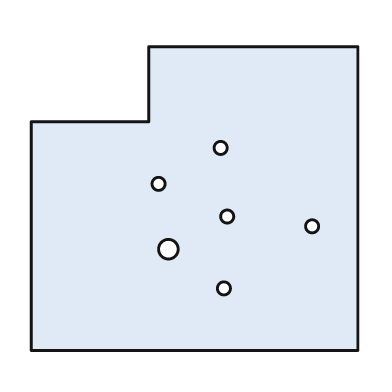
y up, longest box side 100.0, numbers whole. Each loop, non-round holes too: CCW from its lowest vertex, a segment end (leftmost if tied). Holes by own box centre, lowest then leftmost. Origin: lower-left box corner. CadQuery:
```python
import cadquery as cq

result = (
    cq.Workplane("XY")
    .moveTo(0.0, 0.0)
    .lineTo(100.0, 0.0)
    .lineTo(100.0, 93.0)
    .lineTo(36.0, 93.0)
    .lineTo(36.0, 70.0)
    .lineTo(0.0, 70.0)
    .close()
    .moveTo(59.0, 19.0)
    .circle(2.0)
    .moveTo(42.0, 31.0)
    .circle(3.0)
    .moveTo(86.0, 38.0)
    .circle(2.0)
    .moveTo(60.0, 41.0)
    .circle(2.0)
    .moveTo(39.0, 51.0)
    .circle(2.0)
    .moveTo(58.0, 62.0)
    .circle(2.0)
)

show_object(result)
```